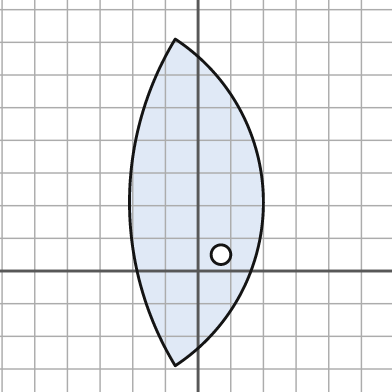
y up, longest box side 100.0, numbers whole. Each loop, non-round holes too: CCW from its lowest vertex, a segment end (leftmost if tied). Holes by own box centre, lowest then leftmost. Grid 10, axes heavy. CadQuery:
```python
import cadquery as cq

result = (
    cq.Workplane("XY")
    .moveTo(-7.0, -29.0)
    .threePointArc((20.0, 21.0), (-7.0, 71.0))
    .threePointArc((-21.0, 21.0), (-7.0, -29.0))
    .close()
    .moveTo(7.0, 5.0)
    .circle(3.0)
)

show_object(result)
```